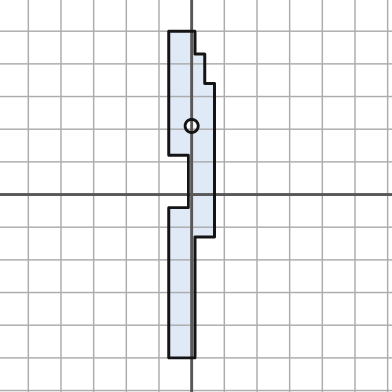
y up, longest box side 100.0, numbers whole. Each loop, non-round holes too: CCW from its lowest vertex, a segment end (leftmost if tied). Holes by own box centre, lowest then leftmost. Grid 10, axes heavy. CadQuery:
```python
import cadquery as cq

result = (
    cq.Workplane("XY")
    .moveTo(-7.0, -50.0)
    .lineTo(1.0, -50.0)
    .lineTo(1.0, -13.0)
    .lineTo(7.0, -13.0)
    .lineTo(7.0, 34.0)
    .lineTo(4.0, 34.0)
    .lineTo(4.0, 43.0)
    .lineTo(1.0, 43.0)
    .lineTo(1.0, 50.0)
    .lineTo(-7.0, 50.0)
    .lineTo(-7.0, 12.0)
    .lineTo(-1.0, 12.0)
    .lineTo(-1.0, -4.0)
    .lineTo(-7.0, -4.0)
    .close()
    .moveTo(0.0, 21.0)
    .circle(2.0)
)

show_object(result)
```